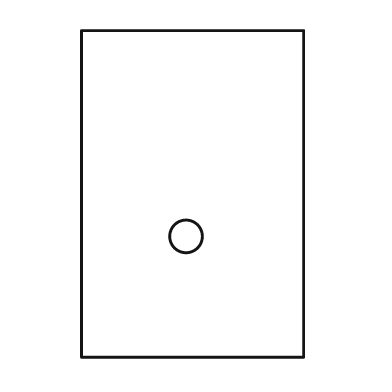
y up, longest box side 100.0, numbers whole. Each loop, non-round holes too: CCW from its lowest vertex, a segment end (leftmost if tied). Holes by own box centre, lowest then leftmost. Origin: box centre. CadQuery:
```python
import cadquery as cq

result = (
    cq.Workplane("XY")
    .moveTo(-34.0, -50.0)
    .lineTo(34.0, -50.0)
    .lineTo(34.0, 50.0)
    .lineTo(-34.0, 50.0)
    .close()
    .moveTo(-2.0, -13.0)
    .circle(5.0)
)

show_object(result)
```